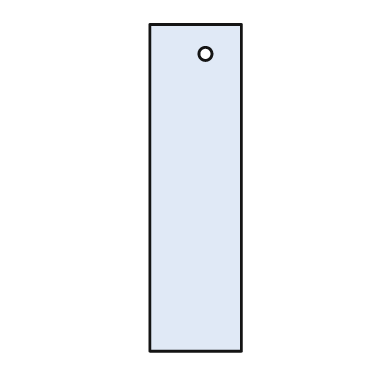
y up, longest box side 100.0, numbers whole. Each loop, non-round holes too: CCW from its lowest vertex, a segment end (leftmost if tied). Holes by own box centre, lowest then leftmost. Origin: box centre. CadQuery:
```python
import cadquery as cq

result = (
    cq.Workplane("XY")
    .moveTo(-14.0, -50.0)
    .lineTo(14.0, -50.0)
    .lineTo(14.0, 50.0)
    .lineTo(-14.0, 50.0)
    .close()
    .moveTo(3.0, 41.0)
    .circle(2.0)
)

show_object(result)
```